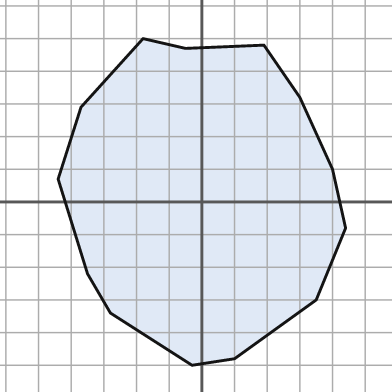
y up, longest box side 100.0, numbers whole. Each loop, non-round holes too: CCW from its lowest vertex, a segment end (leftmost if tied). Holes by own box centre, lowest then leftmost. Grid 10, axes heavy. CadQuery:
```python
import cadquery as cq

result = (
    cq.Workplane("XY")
    .moveTo(-3.0, -50.0)
    .lineTo(10.0, -48.0)
    .lineTo(35.0, -30.0)
    .lineTo(44.0, -8.0)
    .lineTo(40.0, 10.0)
    .lineTo(30.0, 32.0)
    .lineTo(19.0, 48.0)
    .lineTo(-5.0, 47.0)
    .lineTo(-18.0, 50.0)
    .lineTo(-37.0, 29.0)
    .lineTo(-44.0, 7.0)
    .lineTo(-35.0, -22.0)
    .lineTo(-28.0, -34.0)
    .close()
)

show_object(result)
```